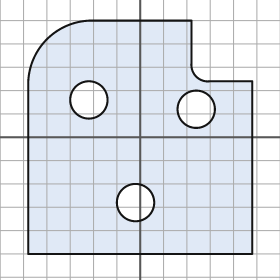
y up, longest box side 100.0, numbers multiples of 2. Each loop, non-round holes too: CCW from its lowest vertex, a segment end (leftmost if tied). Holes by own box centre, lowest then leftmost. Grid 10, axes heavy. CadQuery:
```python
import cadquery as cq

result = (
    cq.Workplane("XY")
    .moveTo(-48.0, -50.0)
    .lineTo(48.0, -50.0)
    .lineTo(48.0, 24.0)
    .lineTo(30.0, 24.0)
    .threePointArc((24.0, 26.0), (22.0, 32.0))
    .lineTo(22.0, 50.0)
    .lineTo(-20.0, 50.0)
    .threePointArc((-40.0, 42.0), (-48.0, 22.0))
    .close()
    .moveTo(-2.0, -28.0)
    .circle(8.0)
    .moveTo(24.0, 12.0)
    .circle(8.0)
    .moveTo(-22.0, 16.0)
    .circle(8.0)
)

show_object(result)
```